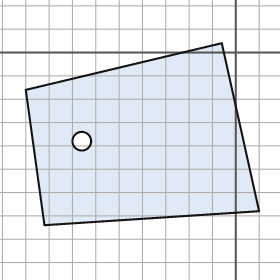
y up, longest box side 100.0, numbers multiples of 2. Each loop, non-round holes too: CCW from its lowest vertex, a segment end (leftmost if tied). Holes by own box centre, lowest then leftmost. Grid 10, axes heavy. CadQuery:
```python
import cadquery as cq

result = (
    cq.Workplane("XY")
    .moveTo(-82.0, -74.0)
    .lineTo(10.0, -68.0)
    .lineTo(-6.0, 4.0)
    .lineTo(-90.0, -16.0)
    .close()
    .moveTo(-66.0, -38.0)
    .circle(4.0)
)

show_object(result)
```